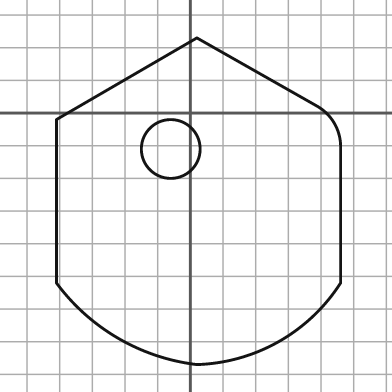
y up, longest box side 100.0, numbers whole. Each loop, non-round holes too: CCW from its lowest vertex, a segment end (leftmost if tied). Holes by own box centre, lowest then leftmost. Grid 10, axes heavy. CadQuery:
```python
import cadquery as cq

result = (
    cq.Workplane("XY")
    .moveTo(2.0, -77.0)
    .threePointArc((27.0, -70.0), (46.0, -52.0))
    .lineTo(46.0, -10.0)
    .threePointArc((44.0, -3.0), (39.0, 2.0))
    .lineTo(2.0, 23.0)
    .lineTo(-41.0, -2.0)
    .lineTo(-41.0, -52.0)
    .threePointArc((-22.0, -69.0), (2.0, -77.0))
    .close()
    .moveTo(-6.0, -11.0)
    .circle(9.0)
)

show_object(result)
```